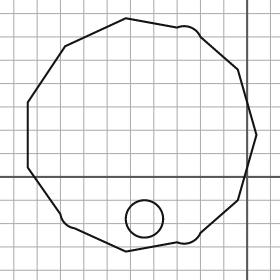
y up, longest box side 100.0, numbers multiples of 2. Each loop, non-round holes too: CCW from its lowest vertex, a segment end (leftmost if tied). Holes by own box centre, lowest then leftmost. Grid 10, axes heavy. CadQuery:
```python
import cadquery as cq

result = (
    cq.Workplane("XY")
    .moveTo(-52.0, -32.0)
    .lineTo(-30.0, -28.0)
    .threePointArc((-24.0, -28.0), (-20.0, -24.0))
    .lineTo(-4.0, -10.0)
    .lineTo(4.0, 18.0)
    .lineTo(-4.0, 46.0)
    .lineTo(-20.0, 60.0)
    .threePointArc((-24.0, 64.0), (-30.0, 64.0))
    .lineTo(-52.0, 68.0)
    .lineTo(-78.0, 56.0)
    .lineTo(-94.0, 32.0)
    .lineTo(-94.0, 4.0)
    .lineTo(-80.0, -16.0)
    .threePointArc((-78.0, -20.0), (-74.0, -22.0))
    .close()
    .moveTo(-44.0, -18.0)
    .circle(8.0)
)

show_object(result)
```